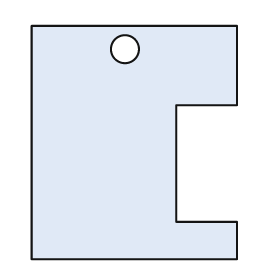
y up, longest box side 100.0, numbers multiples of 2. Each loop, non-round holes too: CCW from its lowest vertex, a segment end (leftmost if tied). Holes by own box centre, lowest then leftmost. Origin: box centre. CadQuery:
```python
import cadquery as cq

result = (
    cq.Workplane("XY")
    .moveTo(-44.0, -50.0)
    .lineTo(44.0, -50.0)
    .lineTo(44.0, -34.0)
    .lineTo(18.0, -34.0)
    .lineTo(18.0, 16.0)
    .lineTo(44.0, 16.0)
    .lineTo(44.0, 50.0)
    .lineTo(-44.0, 50.0)
    .close()
    .moveTo(-4.0, 40.0)
    .circle(6.0)
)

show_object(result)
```